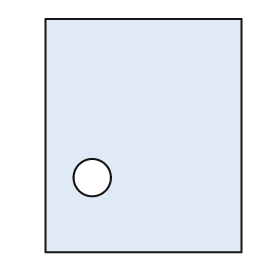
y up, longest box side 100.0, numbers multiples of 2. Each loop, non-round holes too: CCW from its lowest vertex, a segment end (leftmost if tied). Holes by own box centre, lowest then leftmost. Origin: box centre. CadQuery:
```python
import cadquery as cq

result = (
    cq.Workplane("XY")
    .moveTo(-42.0, -50.0)
    .lineTo(42.0, -50.0)
    .lineTo(42.0, 50.0)
    .lineTo(-42.0, 50.0)
    .close()
    .moveTo(-22.0, -18.0)
    .circle(8.0)
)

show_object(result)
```